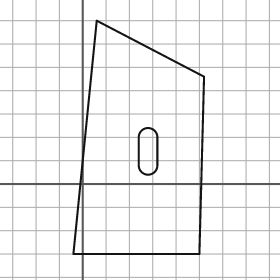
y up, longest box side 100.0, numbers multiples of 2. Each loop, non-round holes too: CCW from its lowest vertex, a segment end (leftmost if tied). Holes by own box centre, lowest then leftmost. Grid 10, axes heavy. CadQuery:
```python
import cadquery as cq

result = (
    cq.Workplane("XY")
    .moveTo(-4.0, -30.0)
    .lineTo(50.0, -30.0)
    .lineTo(52.0, 46.0)
    .lineTo(6.0, 70.0)
    .close()
    .moveTo(24.0, 8.0)
    .threePointArc((28.0, 4.0), (32.0, 8.0))
    .lineTo(32.0, 20.0)
    .threePointArc((28.0, 24.0), (24.0, 20.0))
    .close()
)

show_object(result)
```